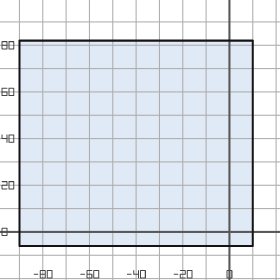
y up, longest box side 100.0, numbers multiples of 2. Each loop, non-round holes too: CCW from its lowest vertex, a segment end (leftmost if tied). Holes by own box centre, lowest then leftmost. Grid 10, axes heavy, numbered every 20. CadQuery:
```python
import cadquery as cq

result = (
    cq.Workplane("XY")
    .moveTo(-90.0, -6.0)
    .lineTo(10.0, -6.0)
    .lineTo(10.0, 82.0)
    .lineTo(-90.0, 82.0)
    .close()
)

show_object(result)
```